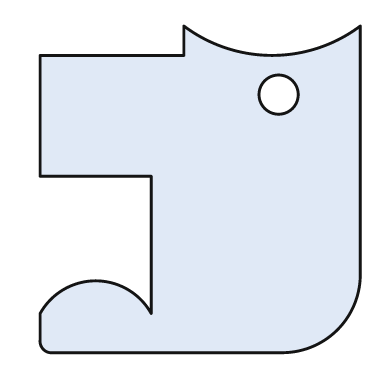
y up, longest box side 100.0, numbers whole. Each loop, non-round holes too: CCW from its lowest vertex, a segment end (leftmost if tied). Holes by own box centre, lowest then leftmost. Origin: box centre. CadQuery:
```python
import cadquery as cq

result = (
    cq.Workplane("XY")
    .moveTo(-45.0, -50.0)
    .lineTo(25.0, -50.0)
    .threePointArc((42.0, -43.0), (49.0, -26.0))
    .lineTo(49.0, 50.0)
    .threePointArc((22.0, 41.0), (-5.0, 50.0))
    .lineTo(-5.0, 41.0)
    .lineTo(-49.0, 41.0)
    .lineTo(-49.0, 4.0)
    .lineTo(-15.0, 4.0)
    .lineTo(-15.0, -38.0)
    .threePointArc((-32.0, -28.0), (-49.0, -38.0))
    .lineTo(-49.0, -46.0)
    .threePointArc((-48.0, -49.0), (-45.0, -50.0))
    .close()
    .moveTo(24.0, 29.0)
    .circle(6.0)
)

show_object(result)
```